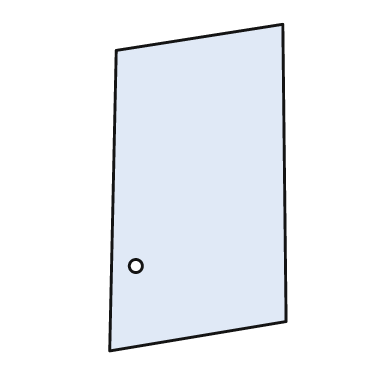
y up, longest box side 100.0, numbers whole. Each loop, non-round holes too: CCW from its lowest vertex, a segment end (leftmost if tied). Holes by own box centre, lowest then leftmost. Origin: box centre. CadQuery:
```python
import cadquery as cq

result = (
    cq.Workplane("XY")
    .moveTo(-27.0, -50.0)
    .lineTo(27.0, -41.0)
    .lineTo(26.0, 50.0)
    .lineTo(-25.0, 42.0)
    .close()
    .moveTo(-19.0, -24.0)
    .circle(2.0)
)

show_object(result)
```